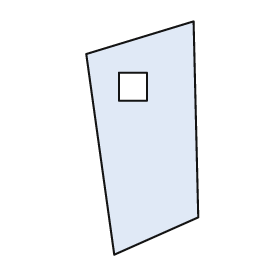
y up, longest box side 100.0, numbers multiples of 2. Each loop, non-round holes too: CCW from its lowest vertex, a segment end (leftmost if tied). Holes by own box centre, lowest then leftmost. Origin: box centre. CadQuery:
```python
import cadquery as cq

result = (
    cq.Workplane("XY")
    .moveTo(-12.0, -50.0)
    .lineTo(24.0, -34.0)
    .lineTo(22.0, 50.0)
    .lineTo(-24.0, 36.0)
    .close()
    .moveTo(-10.0, 16.0)
    .lineTo(2.0, 16.0)
    .lineTo(2.0, 28.0)
    .lineTo(-10.0, 28.0)
    .close()
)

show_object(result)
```